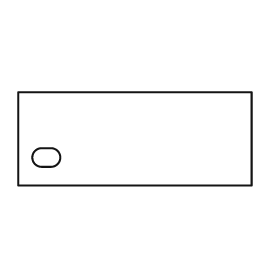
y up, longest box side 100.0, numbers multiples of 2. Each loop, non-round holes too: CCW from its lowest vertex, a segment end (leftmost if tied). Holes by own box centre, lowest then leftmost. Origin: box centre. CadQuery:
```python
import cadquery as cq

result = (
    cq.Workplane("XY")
    .moveTo(-50.0, -20.0)
    .lineTo(50.0, -20.0)
    .lineTo(50.0, 20.0)
    .lineTo(-50.0, 20.0)
    .close()
    .moveTo(-40.0, -12.0)
    .lineTo(-36.0, -12.0)
    .threePointArc((-32.0, -8.0), (-36.0, -4.0))
    .lineTo(-40.0, -4.0)
    .threePointArc((-44.0, -8.0), (-40.0, -12.0))
    .close()
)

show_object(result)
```